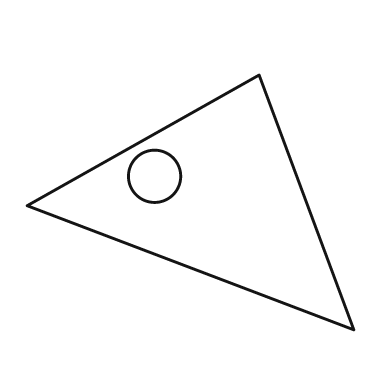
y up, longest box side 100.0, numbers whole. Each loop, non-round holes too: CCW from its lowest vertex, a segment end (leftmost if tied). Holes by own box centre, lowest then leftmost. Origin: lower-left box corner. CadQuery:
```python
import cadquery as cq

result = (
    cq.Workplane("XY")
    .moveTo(100.0, 0.0)
    .lineTo(71.0, 78.0)
    .lineTo(0.0, 38.0)
    .close()
    .moveTo(39.0, 47.0)
    .circle(8.0)
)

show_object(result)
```